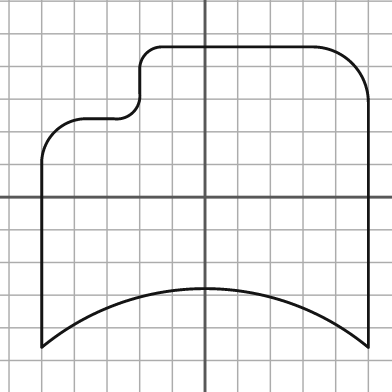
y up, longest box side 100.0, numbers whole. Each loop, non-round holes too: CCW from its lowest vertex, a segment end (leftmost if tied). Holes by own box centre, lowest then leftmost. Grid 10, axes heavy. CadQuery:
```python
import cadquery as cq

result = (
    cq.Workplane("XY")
    .moveTo(-50.0, -46.0)
    .threePointArc((0.0, -28.0), (50.0, -46.0))
    .lineTo(50.0, 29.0)
    .threePointArc((45.0, 41.0), (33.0, 46.0))
    .lineTo(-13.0, 46.0)
    .threePointArc((-18.0, 44.0), (-20.0, 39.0))
    .lineTo(-20.0, 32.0)
    .threePointArc((-22.0, 26.0), (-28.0, 24.0))
    .lineTo(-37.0, 24.0)
    .threePointArc((-46.0, 20.0), (-50.0, 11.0))
    .close()
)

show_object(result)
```